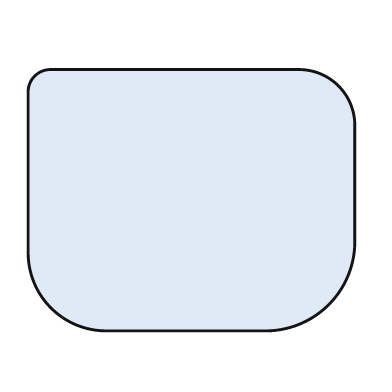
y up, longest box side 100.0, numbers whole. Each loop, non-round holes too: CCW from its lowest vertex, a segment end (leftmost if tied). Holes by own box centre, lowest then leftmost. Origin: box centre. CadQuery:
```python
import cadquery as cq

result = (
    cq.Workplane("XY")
    .moveTo(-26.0, -40.0)
    .lineTo(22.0, -40.0)
    .threePointArc((42.0, -32.0), (50.0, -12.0))
    .lineTo(50.0, 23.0)
    .threePointArc((45.0, 35.0), (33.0, 40.0))
    .lineTo(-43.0, 40.0)
    .threePointArc((-48.0, 38.0), (-50.0, 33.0))
    .lineTo(-50.0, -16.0)
    .threePointArc((-43.0, -33.0), (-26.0, -40.0))
    .close()
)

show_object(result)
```